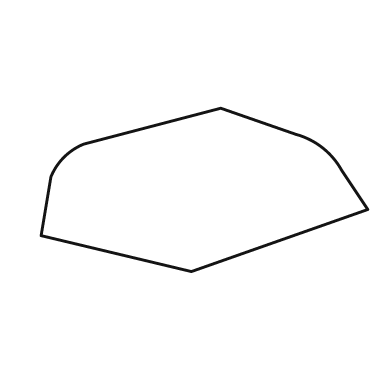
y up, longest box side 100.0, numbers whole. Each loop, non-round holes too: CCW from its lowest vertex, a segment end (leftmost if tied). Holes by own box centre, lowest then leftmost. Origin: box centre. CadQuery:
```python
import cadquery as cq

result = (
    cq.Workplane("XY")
    .moveTo(-4.0, -25.0)
    .lineTo(50.0, -6.0)
    .lineTo(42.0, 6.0)
    .threePointArc((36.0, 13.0), (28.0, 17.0))
    .lineTo(5.0, 25.0)
    .lineTo(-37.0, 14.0)
    .threePointArc((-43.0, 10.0), (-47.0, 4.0))
    .lineTo(-50.0, -14.0)
    .close()
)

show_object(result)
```